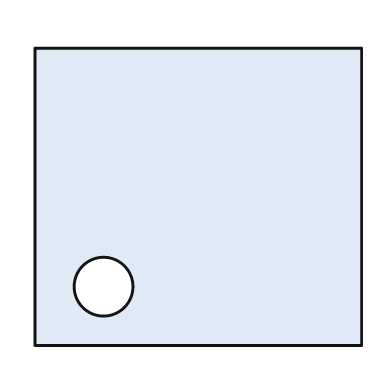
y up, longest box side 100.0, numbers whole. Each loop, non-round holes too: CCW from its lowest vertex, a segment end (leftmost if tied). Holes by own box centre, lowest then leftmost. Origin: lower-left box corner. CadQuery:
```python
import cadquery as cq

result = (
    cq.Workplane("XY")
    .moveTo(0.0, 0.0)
    .lineTo(100.0, 0.0)
    .lineTo(100.0, 91.0)
    .lineTo(0.0, 91.0)
    .close()
    .moveTo(21.0, 18.0)
    .circle(9.0)
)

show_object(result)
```